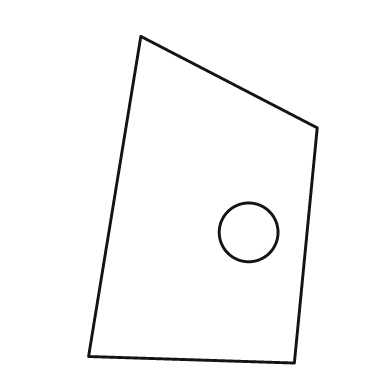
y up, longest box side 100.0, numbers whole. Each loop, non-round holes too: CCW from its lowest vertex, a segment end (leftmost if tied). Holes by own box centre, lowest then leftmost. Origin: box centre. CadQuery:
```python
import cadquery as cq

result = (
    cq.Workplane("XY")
    .moveTo(28.0, -50.0)
    .lineTo(35.0, 22.0)
    .lineTo(-19.0, 50.0)
    .lineTo(-35.0, -48.0)
    .close()
    .moveTo(14.0, -10.0)
    .circle(9.0)
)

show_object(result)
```